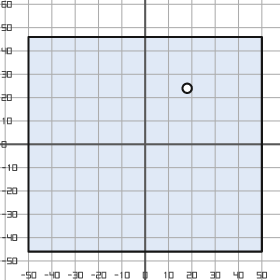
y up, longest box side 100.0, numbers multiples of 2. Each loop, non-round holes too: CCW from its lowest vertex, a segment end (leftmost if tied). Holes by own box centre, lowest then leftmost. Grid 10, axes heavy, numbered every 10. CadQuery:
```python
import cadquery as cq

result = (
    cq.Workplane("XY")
    .moveTo(-50.0, -46.0)
    .lineTo(50.0, -46.0)
    .lineTo(50.0, 46.0)
    .lineTo(-50.0, 46.0)
    .close()
    .moveTo(18.0, 24.0)
    .circle(2.0)
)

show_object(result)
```